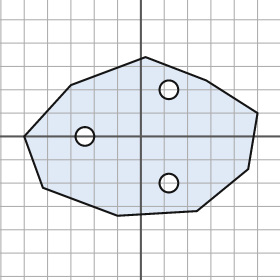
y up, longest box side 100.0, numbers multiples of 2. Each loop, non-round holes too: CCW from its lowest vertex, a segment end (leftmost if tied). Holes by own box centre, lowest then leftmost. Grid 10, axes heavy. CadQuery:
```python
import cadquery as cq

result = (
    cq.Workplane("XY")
    .moveTo(-10.0, -34.0)
    .lineTo(24.0, -32.0)
    .lineTo(46.0, -14.0)
    .lineTo(50.0, 10.0)
    .lineTo(28.0, 24.0)
    .lineTo(2.0, 34.0)
    .lineTo(-30.0, 22.0)
    .lineTo(-50.0, 0.0)
    .lineTo(-42.0, -22.0)
    .close()
    .moveTo(12.0, -20.0)
    .circle(4.0)
    .moveTo(-24.0, 0.0)
    .circle(4.0)
    .moveTo(12.0, 20.0)
    .circle(4.0)
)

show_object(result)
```